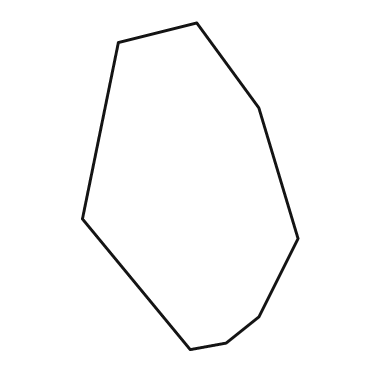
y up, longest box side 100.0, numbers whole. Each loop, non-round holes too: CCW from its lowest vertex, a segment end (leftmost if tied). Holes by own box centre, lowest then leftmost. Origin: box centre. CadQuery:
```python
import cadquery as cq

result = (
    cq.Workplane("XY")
    .moveTo(0.0, -50.0)
    .lineTo(11.0, -48.0)
    .lineTo(21.0, -40.0)
    .lineTo(33.0, -16.0)
    .lineTo(21.0, 24.0)
    .lineTo(2.0, 50.0)
    .lineTo(-22.0, 44.0)
    .lineTo(-33.0, -10.0)
    .close()
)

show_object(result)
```